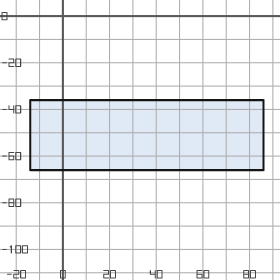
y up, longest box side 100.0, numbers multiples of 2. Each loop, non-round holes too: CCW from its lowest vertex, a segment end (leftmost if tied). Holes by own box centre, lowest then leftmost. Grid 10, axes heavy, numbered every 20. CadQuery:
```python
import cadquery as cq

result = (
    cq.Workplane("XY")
    .moveTo(-14.0, -66.0)
    .lineTo(86.0, -66.0)
    .lineTo(86.0, -36.0)
    .lineTo(-14.0, -36.0)
    .close()
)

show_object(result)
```